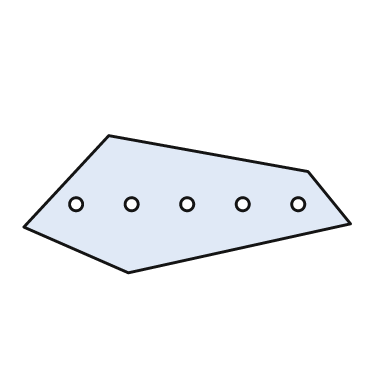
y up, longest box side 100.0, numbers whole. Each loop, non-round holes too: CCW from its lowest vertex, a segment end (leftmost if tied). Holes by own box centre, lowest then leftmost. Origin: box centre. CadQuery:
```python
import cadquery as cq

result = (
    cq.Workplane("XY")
    .moveTo(-18.0, -21.0)
    .lineTo(50.0, -6.0)
    .lineTo(37.0, 10.0)
    .lineTo(-24.0, 21.0)
    .lineTo(-50.0, -7.0)
    .close()
    .moveTo(-34.0, 0.0)
    .circle(2.0)
    .moveTo(-17.0, 0.0)
    .circle(2.0)
    .moveTo(0.0, 0.0)
    .circle(2.0)
    .moveTo(17.0, 0.0)
    .circle(2.0)
    .moveTo(34.0, 0.0)
    .circle(2.0)
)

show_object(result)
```